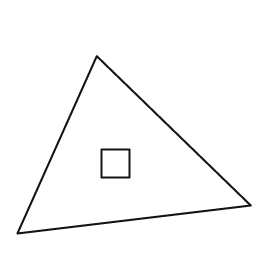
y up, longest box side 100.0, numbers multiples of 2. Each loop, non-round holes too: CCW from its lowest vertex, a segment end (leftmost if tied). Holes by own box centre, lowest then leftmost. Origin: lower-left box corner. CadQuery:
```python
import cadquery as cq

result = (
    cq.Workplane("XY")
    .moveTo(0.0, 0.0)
    .lineTo(100.0, 12.0)
    .lineTo(34.0, 76.0)
    .close()
    .moveTo(36.0, 24.0)
    .lineTo(48.0, 24.0)
    .lineTo(48.0, 36.0)
    .lineTo(36.0, 36.0)
    .close()
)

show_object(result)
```